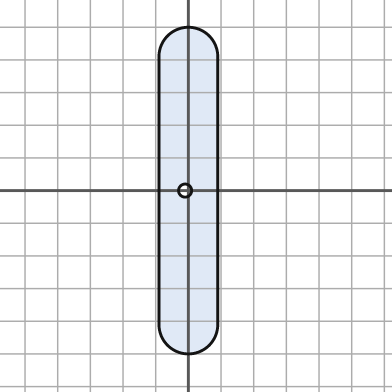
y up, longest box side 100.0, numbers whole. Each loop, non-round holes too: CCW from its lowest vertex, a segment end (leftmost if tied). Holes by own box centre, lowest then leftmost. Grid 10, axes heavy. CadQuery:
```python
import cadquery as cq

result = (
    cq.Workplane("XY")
    .moveTo(-9.0, -41.0)
    .threePointArc((0.0, -50.0), (9.0, -41.0))
    .lineTo(9.0, 41.0)
    .threePointArc((0.0, 50.0), (-9.0, 41.0))
    .close()
    .moveTo(-1.0, 0.0)
    .circle(2.0)
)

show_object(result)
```